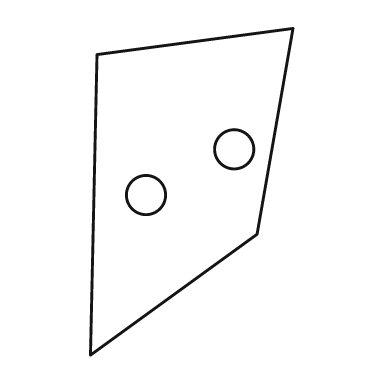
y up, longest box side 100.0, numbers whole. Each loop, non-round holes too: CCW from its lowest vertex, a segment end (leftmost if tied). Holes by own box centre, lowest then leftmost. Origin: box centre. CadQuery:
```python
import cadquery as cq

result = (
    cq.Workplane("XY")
    .moveTo(-31.0, -50.0)
    .lineTo(20.0, -13.0)
    .lineTo(31.0, 50.0)
    .lineTo(-29.0, 42.0)
    .close()
    .moveTo(-14.0, -1.0)
    .circle(6.0)
    .moveTo(13.0, 13.0)
    .circle(6.0)
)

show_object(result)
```